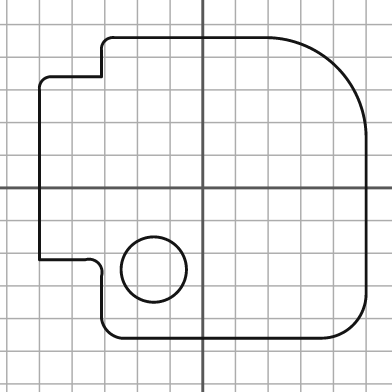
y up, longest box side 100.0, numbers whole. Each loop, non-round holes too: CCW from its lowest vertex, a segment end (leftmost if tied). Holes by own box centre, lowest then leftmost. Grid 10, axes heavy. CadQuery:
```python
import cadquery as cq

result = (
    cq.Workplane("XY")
    .moveTo(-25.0, -46.0)
    .lineTo(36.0, -46.0)
    .threePointArc((46.0, -42.0), (50.0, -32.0))
    .lineTo(50.0, 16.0)
    .threePointArc((41.0, 37.0), (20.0, 46.0))
    .lineTo(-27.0, 46.0)
    .threePointArc((-30.0, 45.0), (-31.0, 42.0))
    .lineTo(-31.0, 34.0)
    .lineTo(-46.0, 34.0)
    .threePointArc((-49.0, 33.0), (-50.0, 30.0))
    .lineTo(-50.0, -22.0)
    .lineTo(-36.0, -22.0)
    .threePointArc((-32.0, -23.0), (-31.0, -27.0))
    .lineTo(-31.0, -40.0)
    .threePointArc((-29.0, -44.0), (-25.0, -46.0))
    .close()
    .moveTo(-15.0, -25.0)
    .circle(10.0)
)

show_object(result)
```